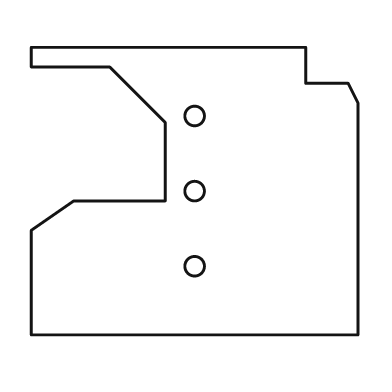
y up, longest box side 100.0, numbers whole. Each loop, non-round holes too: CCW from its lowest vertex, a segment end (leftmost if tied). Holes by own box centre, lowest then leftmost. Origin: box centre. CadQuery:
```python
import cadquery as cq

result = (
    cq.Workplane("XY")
    .moveTo(-50.0, -44.0)
    .lineTo(50.0, -44.0)
    .lineTo(50.0, 27.0)
    .lineTo(47.0, 33.0)
    .lineTo(34.0, 33.0)
    .lineTo(34.0, 44.0)
    .lineTo(-50.0, 44.0)
    .lineTo(-50.0, 38.0)
    .lineTo(-26.0, 38.0)
    .lineTo(-9.0, 21.0)
    .lineTo(-9.0, -3.0)
    .lineTo(-37.0, -3.0)
    .lineTo(-50.0, -12.0)
    .close()
    .moveTo(0.0, -23.0)
    .circle(3.0)
    .moveTo(0.0, 0.0)
    .circle(3.0)
    .moveTo(0.0, 23.0)
    .circle(3.0)
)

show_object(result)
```